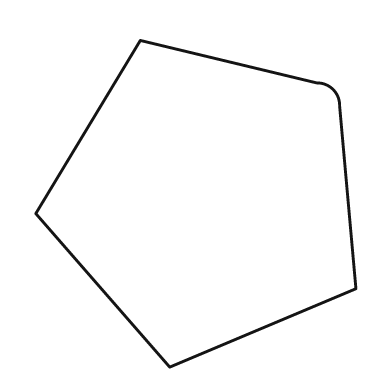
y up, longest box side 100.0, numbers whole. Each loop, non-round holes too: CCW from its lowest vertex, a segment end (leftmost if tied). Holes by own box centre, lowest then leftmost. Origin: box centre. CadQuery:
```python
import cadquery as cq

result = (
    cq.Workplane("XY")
    .moveTo(-8.0, -50.0)
    .lineTo(49.0, -26.0)
    .lineTo(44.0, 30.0)
    .threePointArc((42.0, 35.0), (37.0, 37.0))
    .lineTo(-17.0, 50.0)
    .lineTo(-49.0, -3.0)
    .close()
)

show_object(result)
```